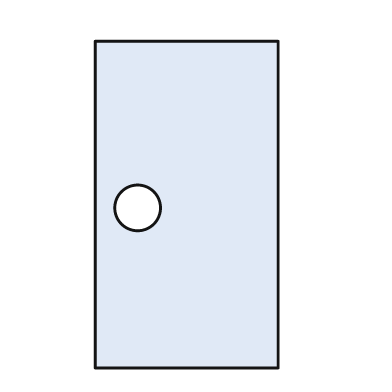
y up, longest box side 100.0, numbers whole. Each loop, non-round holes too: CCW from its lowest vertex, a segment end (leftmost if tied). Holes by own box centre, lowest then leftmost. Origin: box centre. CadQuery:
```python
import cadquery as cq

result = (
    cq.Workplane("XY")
    .moveTo(-28.0, -50.0)
    .lineTo(28.0, -50.0)
    .lineTo(28.0, 50.0)
    .lineTo(-28.0, 50.0)
    .close()
    .moveTo(-15.0, -1.0)
    .circle(7.0)
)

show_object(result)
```